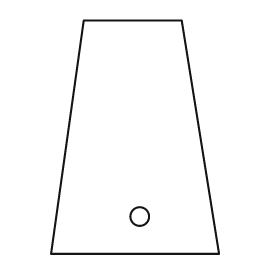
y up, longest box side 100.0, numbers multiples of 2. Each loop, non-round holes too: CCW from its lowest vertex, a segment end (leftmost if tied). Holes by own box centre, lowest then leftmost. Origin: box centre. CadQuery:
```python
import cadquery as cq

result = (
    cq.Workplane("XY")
    .moveTo(-36.0, -50.0)
    .lineTo(36.0, -50.0)
    .lineTo(20.0, 50.0)
    .lineTo(-22.0, 50.0)
    .close()
    .moveTo(2.0, -34.0)
    .circle(4.0)
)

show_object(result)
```